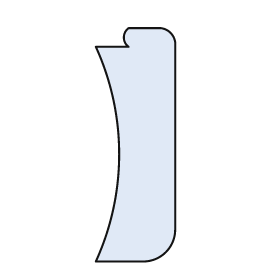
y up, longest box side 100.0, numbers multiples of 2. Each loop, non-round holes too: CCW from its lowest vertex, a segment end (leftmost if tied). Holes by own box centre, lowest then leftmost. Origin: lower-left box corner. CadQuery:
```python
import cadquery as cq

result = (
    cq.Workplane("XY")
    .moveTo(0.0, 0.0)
    .lineTo(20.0, 0.0)
    .threePointArc((30.0, 4.0), (34.0, 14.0))
    .lineTo(34.0, 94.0)
    .threePointArc((32.0, 98.0), (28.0, 100.0))
    .lineTo(14.0, 100.0)
    .threePointArc((12.0, 96.0), (14.0, 92.0))
    .lineTo(0.0, 92.0)
    .threePointArc((10.0, 46.0), (0.0, 0.0))
    .close()
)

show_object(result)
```